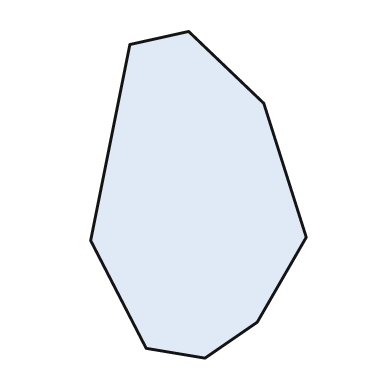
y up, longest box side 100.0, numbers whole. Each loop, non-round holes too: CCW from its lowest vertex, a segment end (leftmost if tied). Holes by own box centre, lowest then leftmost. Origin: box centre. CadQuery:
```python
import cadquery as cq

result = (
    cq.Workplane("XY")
    .moveTo(2.0, -50.0)
    .lineTo(18.0, -39.0)
    .lineTo(33.0, -13.0)
    .lineTo(20.0, 28.0)
    .lineTo(-3.0, 50.0)
    .lineTo(-21.0, 46.0)
    .lineTo(-33.0, -14.0)
    .lineTo(-16.0, -47.0)
    .close()
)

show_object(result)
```